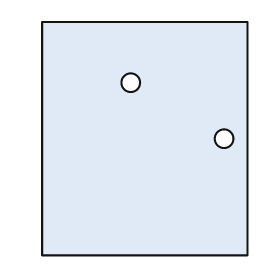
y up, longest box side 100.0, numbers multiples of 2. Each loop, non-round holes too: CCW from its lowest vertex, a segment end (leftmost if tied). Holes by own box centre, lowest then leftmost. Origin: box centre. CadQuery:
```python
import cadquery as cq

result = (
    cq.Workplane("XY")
    .moveTo(-44.0, -50.0)
    .lineTo(44.0, -50.0)
    .lineTo(44.0, 50.0)
    .lineTo(-44.0, 50.0)
    .close()
    .moveTo(34.0, 0.0)
    .circle(4.0)
    .moveTo(-6.0, 24.0)
    .circle(4.0)
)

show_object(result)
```